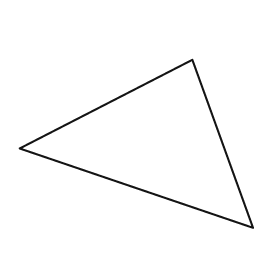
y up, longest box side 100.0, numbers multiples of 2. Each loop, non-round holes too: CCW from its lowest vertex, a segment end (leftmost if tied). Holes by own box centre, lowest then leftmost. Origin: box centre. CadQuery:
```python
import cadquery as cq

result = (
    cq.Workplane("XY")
    .moveTo(50.0, -36.0)
    .lineTo(24.0, 36.0)
    .lineTo(-50.0, -2.0)
    .close()
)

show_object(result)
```